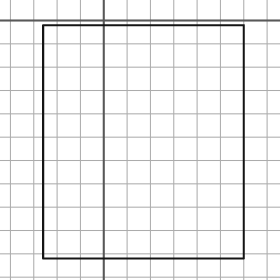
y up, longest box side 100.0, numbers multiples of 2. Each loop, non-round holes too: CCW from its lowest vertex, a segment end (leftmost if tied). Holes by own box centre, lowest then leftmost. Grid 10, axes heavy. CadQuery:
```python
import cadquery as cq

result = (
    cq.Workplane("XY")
    .moveTo(-26.0, -102.0)
    .lineTo(60.0, -102.0)
    .lineTo(60.0, -2.0)
    .lineTo(-26.0, -2.0)
    .close()
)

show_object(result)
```